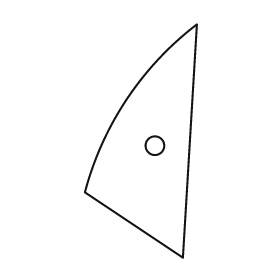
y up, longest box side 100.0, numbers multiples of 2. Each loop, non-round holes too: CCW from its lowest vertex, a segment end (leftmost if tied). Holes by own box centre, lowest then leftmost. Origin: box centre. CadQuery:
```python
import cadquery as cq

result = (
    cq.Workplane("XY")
    .moveTo(18.0, -50.0)
    .lineTo(24.0, 50.0)
    .threePointArc((-6.0, 18.0), (-24.0, -22.0))
    .close()
    .moveTo(6.0, -2.0)
    .circle(4.0)
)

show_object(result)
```